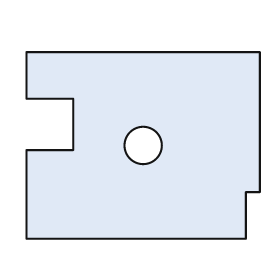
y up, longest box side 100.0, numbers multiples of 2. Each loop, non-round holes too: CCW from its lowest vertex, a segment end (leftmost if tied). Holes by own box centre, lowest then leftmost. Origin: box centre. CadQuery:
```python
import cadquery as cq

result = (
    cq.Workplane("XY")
    .moveTo(-50.0, -40.0)
    .lineTo(44.0, -40.0)
    .lineTo(44.0, -20.0)
    .lineTo(50.0, -20.0)
    .lineTo(50.0, 40.0)
    .lineTo(-50.0, 40.0)
    .lineTo(-50.0, 20.0)
    .lineTo(-30.0, 20.0)
    .lineTo(-30.0, -2.0)
    .lineTo(-50.0, -2.0)
    .close()
    .moveTo(0.0, 0.0)
    .circle(8.0)
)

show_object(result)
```